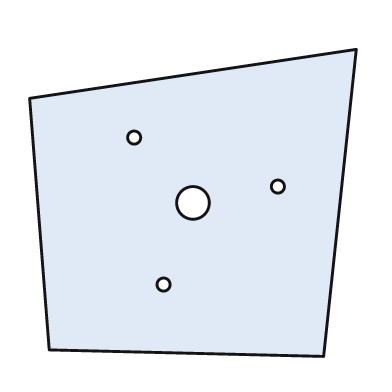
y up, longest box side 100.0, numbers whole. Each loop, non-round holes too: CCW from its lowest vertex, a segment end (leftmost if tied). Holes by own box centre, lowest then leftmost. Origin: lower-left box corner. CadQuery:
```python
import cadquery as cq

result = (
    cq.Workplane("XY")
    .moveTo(90.0, 0.0)
    .lineTo(100.0, 94.0)
    .lineTo(0.0, 79.0)
    .lineTo(6.0, 2.0)
    .close()
    .moveTo(41.0, 22.0)
    .circle(2.0)
    .moveTo(50.0, 47.0)
    .circle(5.0)
    .moveTo(76.0, 52.0)
    .circle(2.0)
    .moveTo(32.0, 67.0)
    .circle(2.0)
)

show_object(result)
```